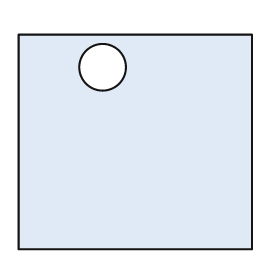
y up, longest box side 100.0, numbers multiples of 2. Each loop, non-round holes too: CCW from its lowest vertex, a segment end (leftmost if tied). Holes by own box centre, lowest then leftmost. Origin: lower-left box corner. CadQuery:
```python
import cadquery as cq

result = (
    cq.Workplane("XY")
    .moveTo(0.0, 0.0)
    .lineTo(100.0, 0.0)
    .lineTo(100.0, 92.0)
    .lineTo(0.0, 92.0)
    .close()
    .moveTo(36.0, 78.0)
    .circle(10.0)
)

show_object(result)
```